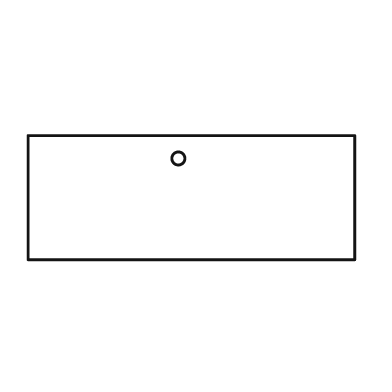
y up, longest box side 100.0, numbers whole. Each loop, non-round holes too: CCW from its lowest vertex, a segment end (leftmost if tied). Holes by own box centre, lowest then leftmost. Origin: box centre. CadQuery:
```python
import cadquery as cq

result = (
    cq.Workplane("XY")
    .moveTo(-50.0, -19.0)
    .lineTo(50.0, -19.0)
    .lineTo(50.0, 19.0)
    .lineTo(-50.0, 19.0)
    .close()
    .moveTo(-4.0, 12.0)
    .circle(2.0)
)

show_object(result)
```